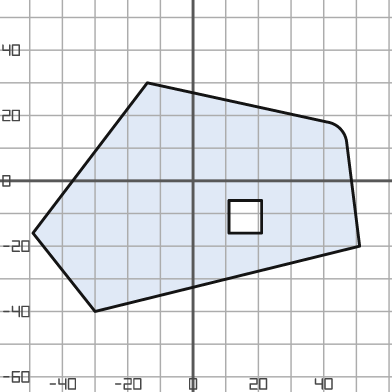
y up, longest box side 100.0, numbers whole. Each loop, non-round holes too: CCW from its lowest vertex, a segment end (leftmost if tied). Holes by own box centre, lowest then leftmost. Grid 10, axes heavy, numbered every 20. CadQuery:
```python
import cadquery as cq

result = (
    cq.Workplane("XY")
    .moveTo(-30.0, -40.0)
    .lineTo(51.0, -20.0)
    .lineTo(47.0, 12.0)
    .threePointArc((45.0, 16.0), (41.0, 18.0))
    .lineTo(-14.0, 30.0)
    .lineTo(-49.0, -16.0)
    .close()
    .moveTo(11.0, -16.0)
    .lineTo(21.0, -16.0)
    .lineTo(21.0, -6.0)
    .lineTo(11.0, -6.0)
    .close()
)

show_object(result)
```